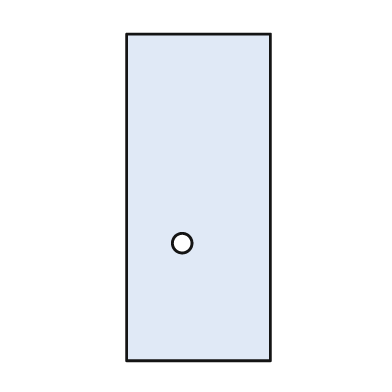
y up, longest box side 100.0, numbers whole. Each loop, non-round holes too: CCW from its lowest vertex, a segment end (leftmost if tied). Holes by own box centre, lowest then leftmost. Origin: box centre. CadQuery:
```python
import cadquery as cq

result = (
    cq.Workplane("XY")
    .moveTo(-22.0, -50.0)
    .lineTo(22.0, -50.0)
    .lineTo(22.0, 50.0)
    .lineTo(-22.0, 50.0)
    .close()
    .moveTo(-5.0, -14.0)
    .circle(3.0)
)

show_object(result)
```